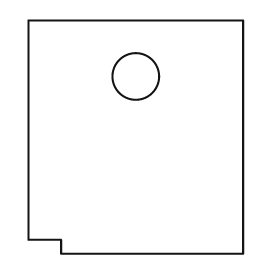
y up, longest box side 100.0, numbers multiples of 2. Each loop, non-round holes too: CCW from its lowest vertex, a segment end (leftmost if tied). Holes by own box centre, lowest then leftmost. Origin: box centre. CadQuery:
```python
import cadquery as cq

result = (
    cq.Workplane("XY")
    .moveTo(-32.0, -50.0)
    .lineTo(46.0, -50.0)
    .lineTo(46.0, 50.0)
    .lineTo(-46.0, 50.0)
    .lineTo(-46.0, -44.0)
    .lineTo(-32.0, -44.0)
    .close()
    .moveTo(0.0, 26.0)
    .circle(10.0)
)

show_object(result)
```